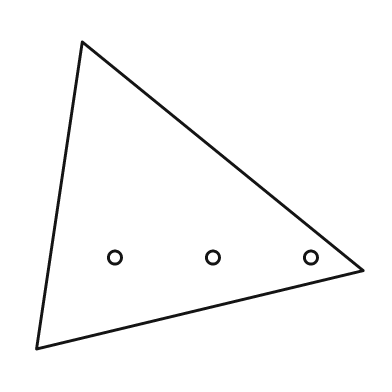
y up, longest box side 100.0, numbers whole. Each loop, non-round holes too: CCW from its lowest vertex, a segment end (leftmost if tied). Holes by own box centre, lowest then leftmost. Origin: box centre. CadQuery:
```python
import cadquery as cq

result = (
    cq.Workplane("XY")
    .moveTo(-50.0, -47.0)
    .lineTo(50.0, -23.0)
    .lineTo(-36.0, 47.0)
    .close()
    .moveTo(-26.0, -19.0)
    .circle(2.0)
    .moveTo(4.0, -19.0)
    .circle(2.0)
    .moveTo(34.0, -19.0)
    .circle(2.0)
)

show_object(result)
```